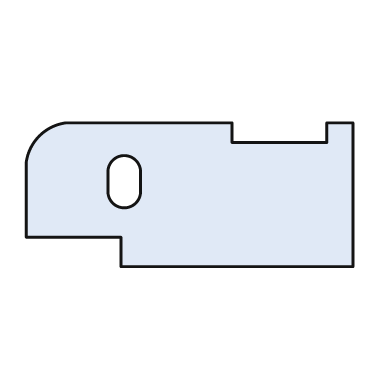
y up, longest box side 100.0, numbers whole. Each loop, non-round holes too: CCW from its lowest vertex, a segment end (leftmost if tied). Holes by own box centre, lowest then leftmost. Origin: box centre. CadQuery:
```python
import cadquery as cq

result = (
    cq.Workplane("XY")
    .moveTo(-21.0, -22.0)
    .lineTo(50.0, -22.0)
    .lineTo(50.0, 22.0)
    .lineTo(42.0, 22.0)
    .lineTo(42.0, 16.0)
    .lineTo(13.0, 16.0)
    .lineTo(13.0, 22.0)
    .lineTo(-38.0, 22.0)
    .threePointArc((-46.0, 18.0), (-50.0, 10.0))
    .lineTo(-50.0, -13.0)
    .lineTo(-21.0, -13.0)
    .close()
    .moveTo(-25.0, 1.0)
    .threePointArc((-20.0, -4.0), (-15.0, 1.0))
    .lineTo(-15.0, 7.0)
    .threePointArc((-20.0, 12.0), (-25.0, 7.0))
    .close()
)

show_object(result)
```